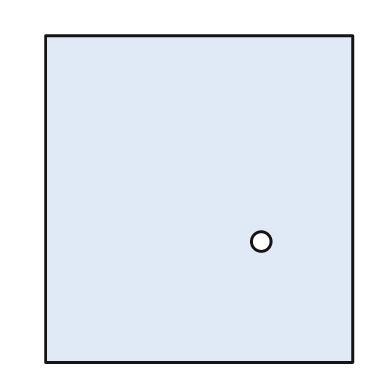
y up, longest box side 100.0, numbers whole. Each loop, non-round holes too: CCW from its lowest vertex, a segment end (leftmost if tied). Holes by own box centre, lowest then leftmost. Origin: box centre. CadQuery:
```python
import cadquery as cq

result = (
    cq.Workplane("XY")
    .moveTo(-47.0, -50.0)
    .lineTo(47.0, -50.0)
    .lineTo(47.0, 50.0)
    .lineTo(-47.0, 50.0)
    .close()
    .moveTo(19.0, -13.0)
    .circle(3.0)
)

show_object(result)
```